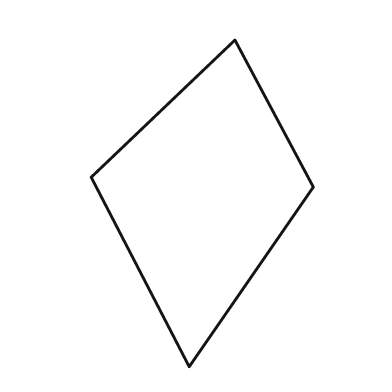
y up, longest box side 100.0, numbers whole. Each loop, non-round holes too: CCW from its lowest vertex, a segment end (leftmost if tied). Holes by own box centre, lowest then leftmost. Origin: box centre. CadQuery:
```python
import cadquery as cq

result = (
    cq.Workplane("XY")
    .moveTo(-4.0, -50.0)
    .lineTo(34.0, 5.0)
    .lineTo(10.0, 50.0)
    .lineTo(-34.0, 8.0)
    .close()
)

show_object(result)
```